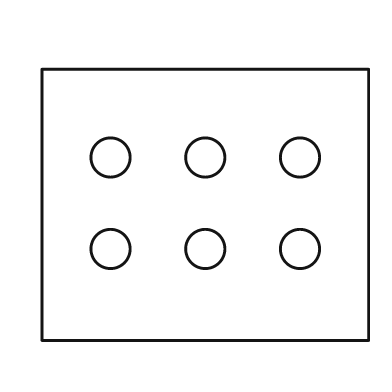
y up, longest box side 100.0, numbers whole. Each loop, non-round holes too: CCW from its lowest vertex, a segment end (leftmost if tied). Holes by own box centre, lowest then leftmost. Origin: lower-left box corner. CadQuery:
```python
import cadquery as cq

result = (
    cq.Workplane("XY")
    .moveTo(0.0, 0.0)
    .lineTo(100.0, 0.0)
    .lineTo(100.0, 83.0)
    .lineTo(0.0, 83.0)
    .close()
    .moveTo(21.0, 28.0)
    .circle(6.0)
    .moveTo(50.0, 28.0)
    .circle(6.0)
    .moveTo(79.0, 28.0)
    .circle(6.0)
    .moveTo(21.0, 56.0)
    .circle(6.0)
    .moveTo(50.0, 56.0)
    .circle(6.0)
    .moveTo(79.0, 56.0)
    .circle(6.0)
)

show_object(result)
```